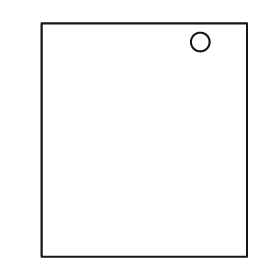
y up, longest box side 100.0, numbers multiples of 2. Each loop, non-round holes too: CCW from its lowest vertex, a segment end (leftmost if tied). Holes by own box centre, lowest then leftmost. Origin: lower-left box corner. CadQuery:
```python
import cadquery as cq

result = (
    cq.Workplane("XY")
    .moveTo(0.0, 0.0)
    .lineTo(88.0, 0.0)
    .lineTo(88.0, 100.0)
    .lineTo(0.0, 100.0)
    .close()
    .moveTo(68.0, 92.0)
    .circle(4.0)
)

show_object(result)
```